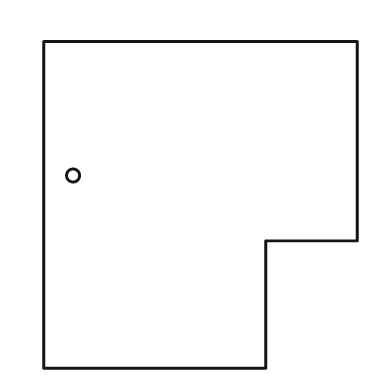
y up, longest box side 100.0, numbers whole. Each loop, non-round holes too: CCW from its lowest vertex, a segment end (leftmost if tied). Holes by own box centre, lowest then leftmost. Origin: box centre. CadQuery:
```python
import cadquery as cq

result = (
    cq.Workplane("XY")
    .moveTo(-48.0, -50.0)
    .lineTo(20.0, -50.0)
    .lineTo(20.0, -11.0)
    .lineTo(48.0, -11.0)
    .lineTo(48.0, 50.0)
    .lineTo(-48.0, 50.0)
    .close()
    .moveTo(-39.0, 9.0)
    .circle(2.0)
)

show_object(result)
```